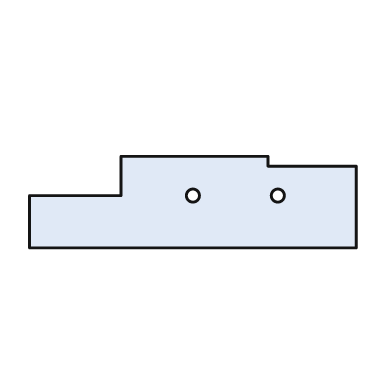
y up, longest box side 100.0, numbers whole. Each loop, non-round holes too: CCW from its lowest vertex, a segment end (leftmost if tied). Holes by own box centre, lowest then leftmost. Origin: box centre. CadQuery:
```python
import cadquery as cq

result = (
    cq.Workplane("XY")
    .moveTo(-50.0, -14.0)
    .lineTo(50.0, -14.0)
    .lineTo(50.0, 11.0)
    .lineTo(23.0, 11.0)
    .lineTo(23.0, 14.0)
    .lineTo(-22.0, 14.0)
    .lineTo(-22.0, 2.0)
    .lineTo(-50.0, 2.0)
    .close()
    .moveTo(0.0, 2.0)
    .circle(2.0)
    .moveTo(26.0, 2.0)
    .circle(2.0)
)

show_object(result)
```